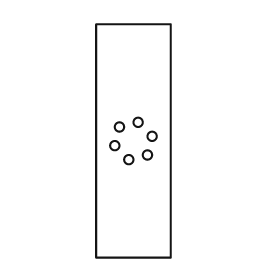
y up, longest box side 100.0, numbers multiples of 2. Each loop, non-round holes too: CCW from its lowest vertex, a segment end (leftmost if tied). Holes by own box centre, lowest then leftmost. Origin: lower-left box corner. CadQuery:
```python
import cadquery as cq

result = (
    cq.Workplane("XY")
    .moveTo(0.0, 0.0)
    .lineTo(32.0, 0.0)
    .lineTo(32.0, 100.0)
    .lineTo(0.0, 100.0)
    .close()
    .moveTo(14.0, 42.0)
    .circle(2.0)
    .moveTo(22.0, 44.0)
    .circle(2.0)
    .moveTo(8.0, 48.0)
    .circle(2.0)
    .moveTo(24.0, 52.0)
    .circle(2.0)
    .moveTo(10.0, 56.0)
    .circle(2.0)
    .moveTo(18.0, 58.0)
    .circle(2.0)
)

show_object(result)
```